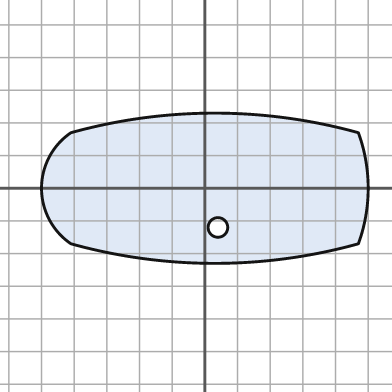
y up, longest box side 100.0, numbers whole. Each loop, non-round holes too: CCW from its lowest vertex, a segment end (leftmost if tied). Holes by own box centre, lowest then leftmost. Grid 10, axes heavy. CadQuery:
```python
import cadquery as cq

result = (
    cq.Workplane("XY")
    .moveTo(-41.0, -17.0)
    .threePointArc((3.0, -23.0), (47.0, -17.0))
    .threePointArc((50.0, 0.0), (47.0, 17.0))
    .threePointArc((3.0, 23.0), (-41.0, 17.0))
    .threePointArc((-50.0, 0.0), (-41.0, -17.0))
    .close()
    .moveTo(4.0, -12.0)
    .circle(3.0)
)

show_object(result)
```